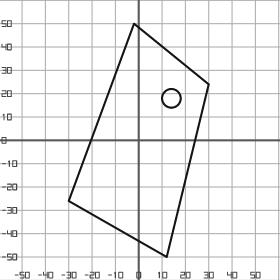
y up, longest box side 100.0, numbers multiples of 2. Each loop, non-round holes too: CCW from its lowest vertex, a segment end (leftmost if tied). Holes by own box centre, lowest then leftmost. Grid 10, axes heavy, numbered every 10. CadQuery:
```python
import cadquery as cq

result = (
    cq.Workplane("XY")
    .moveTo(12.0, -50.0)
    .lineTo(30.0, 24.0)
    .lineTo(-2.0, 50.0)
    .lineTo(-30.0, -26.0)
    .close()
    .moveTo(14.0, 18.0)
    .circle(4.0)
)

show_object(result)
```